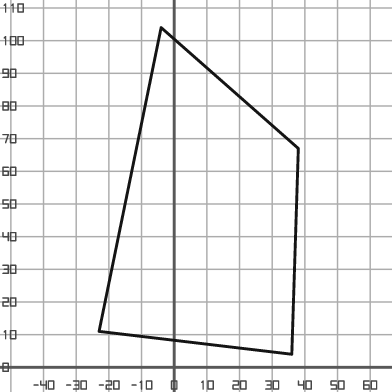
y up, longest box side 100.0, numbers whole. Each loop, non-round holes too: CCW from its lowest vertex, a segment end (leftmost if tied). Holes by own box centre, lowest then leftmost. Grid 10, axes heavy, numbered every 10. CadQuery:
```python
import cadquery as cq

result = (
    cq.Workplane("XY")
    .moveTo(36.0, 4.0)
    .lineTo(38.0, 67.0)
    .lineTo(-4.0, 104.0)
    .lineTo(-23.0, 11.0)
    .close()
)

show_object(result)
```